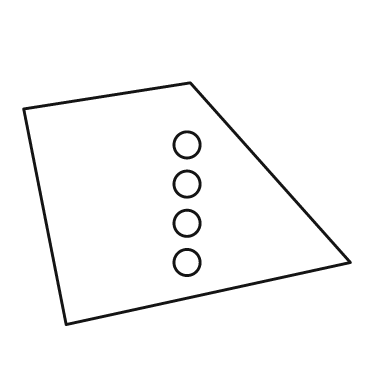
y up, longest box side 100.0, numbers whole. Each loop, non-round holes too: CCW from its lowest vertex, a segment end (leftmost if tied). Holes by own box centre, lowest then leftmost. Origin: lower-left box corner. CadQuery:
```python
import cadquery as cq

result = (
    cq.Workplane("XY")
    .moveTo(13.0, 0.0)
    .lineTo(100.0, 19.0)
    .lineTo(51.0, 74.0)
    .lineTo(0.0, 66.0)
    .close()
    .moveTo(50.0, 19.0)
    .circle(4.0)
    .moveTo(50.0, 31.0)
    .circle(4.0)
    .moveTo(50.0, 43.0)
    .circle(4.0)
    .moveTo(50.0, 55.0)
    .circle(4.0)
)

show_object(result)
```